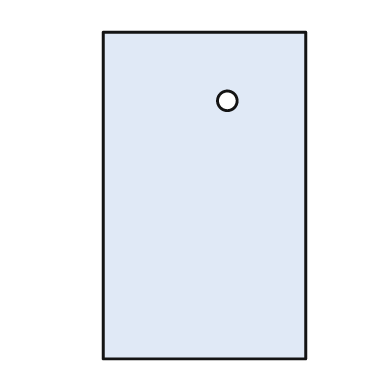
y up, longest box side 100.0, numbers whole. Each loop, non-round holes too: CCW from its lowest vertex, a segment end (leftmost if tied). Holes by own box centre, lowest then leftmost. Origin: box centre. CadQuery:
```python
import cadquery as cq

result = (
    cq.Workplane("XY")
    .moveTo(-31.0, -50.0)
    .lineTo(31.0, -50.0)
    .lineTo(31.0, 50.0)
    .lineTo(-31.0, 50.0)
    .close()
    .moveTo(7.0, 29.0)
    .circle(3.0)
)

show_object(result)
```